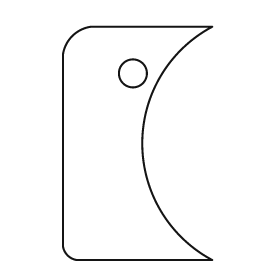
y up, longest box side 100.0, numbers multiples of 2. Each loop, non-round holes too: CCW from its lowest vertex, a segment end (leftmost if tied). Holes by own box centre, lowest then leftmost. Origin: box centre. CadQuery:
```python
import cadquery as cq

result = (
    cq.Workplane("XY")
    .moveTo(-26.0, -50.0)
    .lineTo(32.0, -50.0)
    .threePointArc((2.0, 0.0), (32.0, 50.0))
    .lineTo(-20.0, 50.0)
    .threePointArc((-28.0, 46.0), (-32.0, 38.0))
    .lineTo(-32.0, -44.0)
    .threePointArc((-30.0, -48.0), (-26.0, -50.0))
    .close()
    .moveTo(-2.0, 30.0)
    .circle(6.0)
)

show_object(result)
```